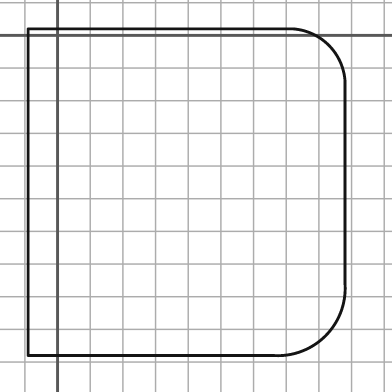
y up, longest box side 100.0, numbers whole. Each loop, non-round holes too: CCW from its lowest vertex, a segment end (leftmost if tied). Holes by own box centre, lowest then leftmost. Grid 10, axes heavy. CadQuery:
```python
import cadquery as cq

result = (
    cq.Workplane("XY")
    .moveTo(-9.0, -98.0)
    .lineTo(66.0, -98.0)
    .threePointArc((82.0, -92.0), (88.0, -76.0))
    .lineTo(88.0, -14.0)
    .threePointArc((83.0, -3.0), (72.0, 2.0))
    .lineTo(-9.0, 2.0)
    .close()
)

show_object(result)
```